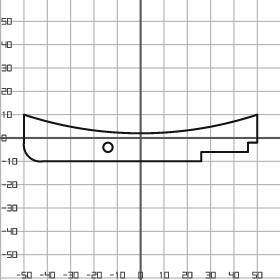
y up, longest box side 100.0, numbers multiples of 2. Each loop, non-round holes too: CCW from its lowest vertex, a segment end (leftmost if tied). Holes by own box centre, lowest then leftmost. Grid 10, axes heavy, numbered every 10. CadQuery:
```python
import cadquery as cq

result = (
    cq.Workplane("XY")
    .moveTo(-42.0, -10.0)
    .lineTo(26.0, -10.0)
    .lineTo(26.0, -6.0)
    .lineTo(46.0, -6.0)
    .lineTo(46.0, -2.0)
    .lineTo(50.0, -2.0)
    .lineTo(50.0, 10.0)
    .threePointArc((0.0, 2.0), (-50.0, 10.0))
    .lineTo(-50.0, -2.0)
    .threePointArc((-48.0, -8.0), (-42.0, -10.0))
    .close()
    .moveTo(-14.0, -4.0)
    .circle(2.0)
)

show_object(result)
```